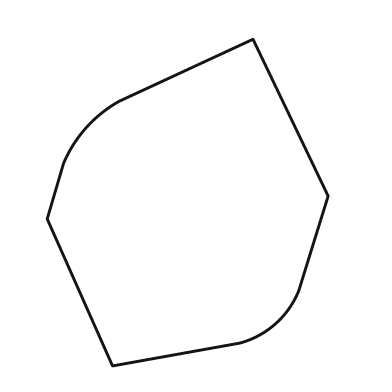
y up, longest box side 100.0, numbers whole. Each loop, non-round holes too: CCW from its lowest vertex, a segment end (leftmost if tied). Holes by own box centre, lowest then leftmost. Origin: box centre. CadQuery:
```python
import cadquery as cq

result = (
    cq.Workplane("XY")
    .moveTo(-23.0, -50.0)
    .lineTo(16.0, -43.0)
    .threePointArc((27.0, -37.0), (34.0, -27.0))
    .lineTo(43.0, 2.0)
    .lineTo(20.0, 50.0)
    .lineTo(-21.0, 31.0)
    .threePointArc((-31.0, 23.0), (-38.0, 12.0))
    .lineTo(-43.0, -5.0)
    .close()
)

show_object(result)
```